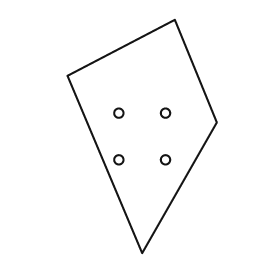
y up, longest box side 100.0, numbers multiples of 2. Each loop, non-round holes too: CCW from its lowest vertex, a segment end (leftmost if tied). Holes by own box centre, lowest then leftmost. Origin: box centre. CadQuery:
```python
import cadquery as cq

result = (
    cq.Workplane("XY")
    .moveTo(0.0, -50.0)
    .lineTo(32.0, 6.0)
    .lineTo(14.0, 50.0)
    .lineTo(-32.0, 26.0)
    .close()
    .moveTo(-10.0, -10.0)
    .circle(2.0)
    .moveTo(10.0, -10.0)
    .circle(2.0)
    .moveTo(-10.0, 10.0)
    .circle(2.0)
    .moveTo(10.0, 10.0)
    .circle(2.0)
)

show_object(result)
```